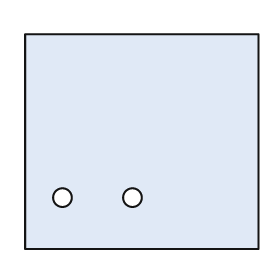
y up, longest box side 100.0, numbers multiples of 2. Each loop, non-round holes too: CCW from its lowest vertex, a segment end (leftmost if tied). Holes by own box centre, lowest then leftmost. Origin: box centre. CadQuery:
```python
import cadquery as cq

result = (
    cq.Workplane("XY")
    .moveTo(-50.0, -46.0)
    .lineTo(50.0, -46.0)
    .lineTo(50.0, 46.0)
    .lineTo(-50.0, 46.0)
    .close()
    .moveTo(-34.0, -24.0)
    .circle(4.0)
    .moveTo(-4.0, -24.0)
    .circle(4.0)
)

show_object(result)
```